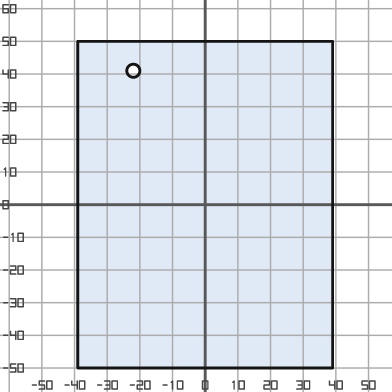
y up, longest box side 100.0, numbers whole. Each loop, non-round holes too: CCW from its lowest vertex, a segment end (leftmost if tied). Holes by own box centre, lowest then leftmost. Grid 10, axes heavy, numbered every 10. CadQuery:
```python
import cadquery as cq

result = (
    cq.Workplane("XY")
    .moveTo(-39.0, -50.0)
    .lineTo(39.0, -50.0)
    .lineTo(39.0, 50.0)
    .lineTo(-39.0, 50.0)
    .close()
    .moveTo(-22.0, 41.0)
    .circle(2.0)
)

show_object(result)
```